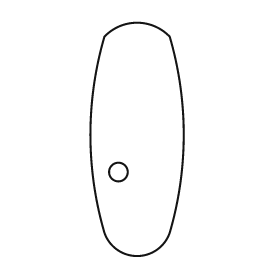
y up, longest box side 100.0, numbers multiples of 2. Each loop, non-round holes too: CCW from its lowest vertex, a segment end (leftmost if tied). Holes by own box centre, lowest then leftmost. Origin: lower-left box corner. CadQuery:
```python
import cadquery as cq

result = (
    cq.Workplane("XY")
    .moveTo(6.0, 10.0)
    .threePointArc((20.0, 0.0), (34.0, 10.0))
    .threePointArc((40.0, 52.0), (34.0, 94.0))
    .threePointArc((20.0, 100.0), (6.0, 94.0))
    .threePointArc((0.0, 52.0), (6.0, 10.0))
    .close()
    .moveTo(12.0, 36.0)
    .circle(4.0)
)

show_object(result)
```